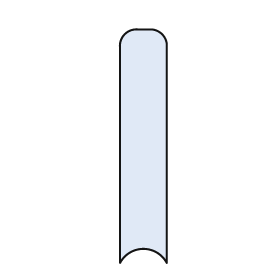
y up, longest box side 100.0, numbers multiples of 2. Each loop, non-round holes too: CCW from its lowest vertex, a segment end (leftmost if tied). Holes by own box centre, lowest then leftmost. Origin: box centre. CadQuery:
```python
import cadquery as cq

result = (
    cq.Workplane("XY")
    .moveTo(-10.0, -50.0)
    .threePointArc((0.0, -44.0), (10.0, -50.0))
    .lineTo(10.0, 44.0)
    .threePointArc((8.0, 48.0), (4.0, 50.0))
    .lineTo(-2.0, 50.0)
    .threePointArc((-8.0, 48.0), (-10.0, 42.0))
    .close()
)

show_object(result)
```